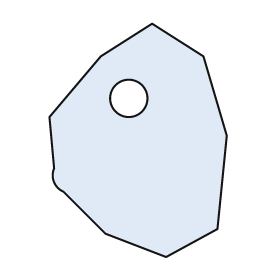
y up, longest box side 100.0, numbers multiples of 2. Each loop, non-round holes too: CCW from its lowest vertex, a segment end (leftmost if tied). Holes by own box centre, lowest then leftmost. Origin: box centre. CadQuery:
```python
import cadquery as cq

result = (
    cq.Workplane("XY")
    .moveTo(12.0, -50.0)
    .lineTo(34.0, -38.0)
    .lineTo(38.0, 2.0)
    .lineTo(28.0, 36.0)
    .lineTo(6.0, 50.0)
    .lineTo(-16.0, 36.0)
    .lineTo(-38.0, 10.0)
    .lineTo(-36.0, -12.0)
    .threePointArc((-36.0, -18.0), (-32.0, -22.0))
    .lineTo(-14.0, -40.0)
    .close()
    .moveTo(-4.0, 18.0)
    .circle(8.0)
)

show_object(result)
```